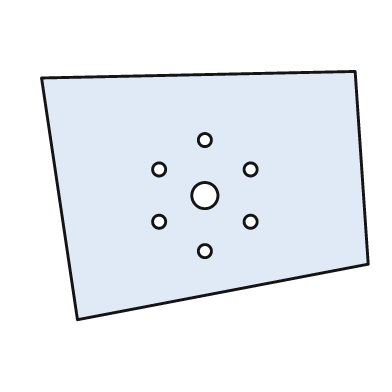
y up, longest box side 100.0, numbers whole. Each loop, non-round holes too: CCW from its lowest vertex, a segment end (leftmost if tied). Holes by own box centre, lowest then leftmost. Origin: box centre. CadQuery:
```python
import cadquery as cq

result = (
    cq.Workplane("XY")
    .moveTo(-39.0, -38.0)
    .lineTo(50.0, -21.0)
    .lineTo(46.0, 38.0)
    .lineTo(-50.0, 36.0)
    .close()
    .moveTo(0.0, -17.0)
    .circle(2.0)
    .moveTo(-14.0, -8.0)
    .circle(2.0)
    .moveTo(14.0, -8.0)
    .circle(2.0)
    .moveTo(0.0, 0.0)
    .circle(4.0)
    .moveTo(-14.0, 8.0)
    .circle(2.0)
    .moveTo(14.0, 8.0)
    .circle(2.0)
    .moveTo(0.0, 17.0)
    .circle(2.0)
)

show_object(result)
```